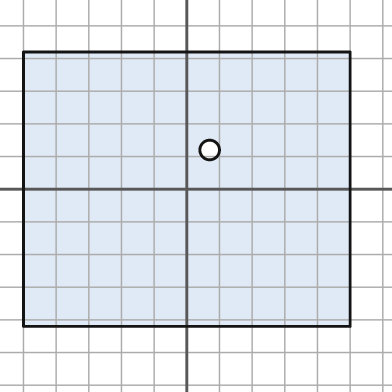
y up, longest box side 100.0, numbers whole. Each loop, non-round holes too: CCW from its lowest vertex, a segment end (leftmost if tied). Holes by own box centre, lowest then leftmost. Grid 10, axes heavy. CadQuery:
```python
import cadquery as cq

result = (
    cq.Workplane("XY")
    .moveTo(-50.0, -42.0)
    .lineTo(50.0, -42.0)
    .lineTo(50.0, 42.0)
    .lineTo(-50.0, 42.0)
    .close()
    .moveTo(7.0, 12.0)
    .circle(3.0)
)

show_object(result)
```